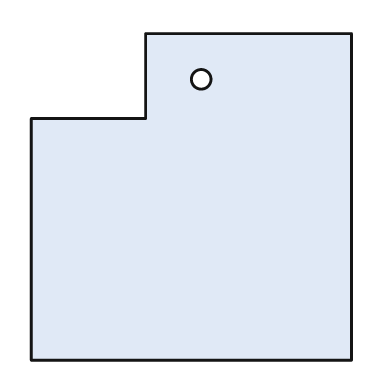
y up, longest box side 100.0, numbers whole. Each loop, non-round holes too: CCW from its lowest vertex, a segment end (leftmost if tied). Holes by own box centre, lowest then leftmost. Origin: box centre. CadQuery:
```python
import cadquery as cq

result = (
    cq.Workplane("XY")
    .moveTo(-49.0, -50.0)
    .lineTo(49.0, -50.0)
    .lineTo(49.0, 50.0)
    .lineTo(-14.0, 50.0)
    .lineTo(-14.0, 24.0)
    .lineTo(-49.0, 24.0)
    .close()
    .moveTo(3.0, 36.0)
    .circle(3.0)
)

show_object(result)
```